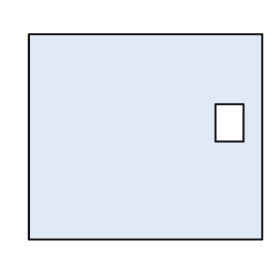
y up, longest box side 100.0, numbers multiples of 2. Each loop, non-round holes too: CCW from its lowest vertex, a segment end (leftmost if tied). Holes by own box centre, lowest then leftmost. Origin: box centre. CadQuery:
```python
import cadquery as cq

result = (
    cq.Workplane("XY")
    .moveTo(-50.0, -44.0)
    .lineTo(50.0, -44.0)
    .lineTo(50.0, 44.0)
    .lineTo(-50.0, 44.0)
    .close()
    .moveTo(30.0, -2.0)
    .lineTo(42.0, -2.0)
    .lineTo(42.0, 14.0)
    .lineTo(30.0, 14.0)
    .close()
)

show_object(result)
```